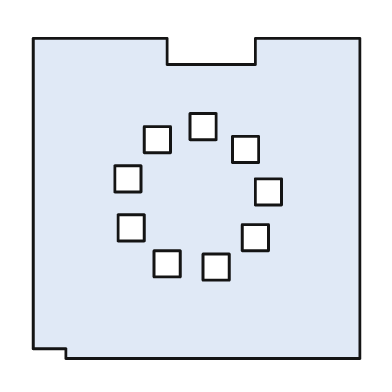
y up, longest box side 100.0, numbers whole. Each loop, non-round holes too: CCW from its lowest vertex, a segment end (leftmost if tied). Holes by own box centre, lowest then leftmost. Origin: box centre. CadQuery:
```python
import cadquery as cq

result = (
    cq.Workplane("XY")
    .moveTo(-40.0, -49.0)
    .lineTo(50.0, -49.0)
    .lineTo(50.0, 49.0)
    .lineTo(18.0, 49.0)
    .lineTo(18.0, 41.0)
    .lineTo(-9.0, 41.0)
    .lineTo(-9.0, 49.0)
    .lineTo(-50.0, 49.0)
    .lineTo(-50.0, -46.0)
    .lineTo(-40.0, -46.0)
    .close()
    .moveTo(2.0, -25.0)
    .lineTo(10.0, -25.0)
    .lineTo(10.0, -17.0)
    .lineTo(2.0, -17.0)
    .close()
    .moveTo(-13.0, -24.0)
    .lineTo(-5.0, -24.0)
    .lineTo(-5.0, -16.0)
    .lineTo(-13.0, -16.0)
    .close()
    .moveTo(14.0, -16.0)
    .lineTo(22.0, -16.0)
    .lineTo(22.0, -8.0)
    .lineTo(14.0, -8.0)
    .close()
    .moveTo(-24.0, -13.0)
    .lineTo(-16.0, -13.0)
    .lineTo(-16.0, -5.0)
    .lineTo(-24.0, -5.0)
    .close()
    .moveTo(18.0, -2.0)
    .lineTo(26.0, -2.0)
    .lineTo(26.0, 6.0)
    .lineTo(18.0, 6.0)
    .close()
    .moveTo(-25.0, 2.0)
    .lineTo(-17.0, 2.0)
    .lineTo(-17.0, 10.0)
    .lineTo(-25.0, 10.0)
    .close()
    .moveTo(11.0, 11.0)
    .lineTo(19.0, 11.0)
    .lineTo(19.0, 19.0)
    .lineTo(11.0, 19.0)
    .close()
    .moveTo(-16.0, 14.0)
    .lineTo(-8.0, 14.0)
    .lineTo(-8.0, 22.0)
    .lineTo(-16.0, 22.0)
    .close()
    .moveTo(-2.0, 18.0)
    .lineTo(6.0, 18.0)
    .lineTo(6.0, 26.0)
    .lineTo(-2.0, 26.0)
    .close()
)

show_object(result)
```